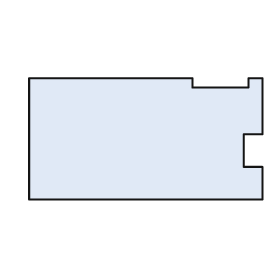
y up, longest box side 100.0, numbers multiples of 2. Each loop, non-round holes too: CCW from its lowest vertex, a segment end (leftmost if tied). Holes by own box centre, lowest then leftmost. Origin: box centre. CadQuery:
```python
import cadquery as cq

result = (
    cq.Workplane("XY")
    .moveTo(-50.0, -26.0)
    .lineTo(50.0, -26.0)
    .lineTo(50.0, -12.0)
    .lineTo(42.0, -12.0)
    .lineTo(42.0, 2.0)
    .lineTo(50.0, 2.0)
    .lineTo(50.0, 26.0)
    .lineTo(44.0, 26.0)
    .lineTo(44.0, 22.0)
    .lineTo(20.0, 22.0)
    .lineTo(20.0, 26.0)
    .lineTo(-50.0, 26.0)
    .close()
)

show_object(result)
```